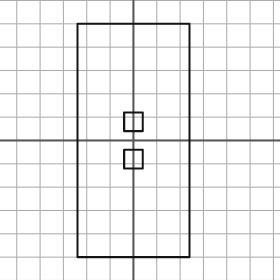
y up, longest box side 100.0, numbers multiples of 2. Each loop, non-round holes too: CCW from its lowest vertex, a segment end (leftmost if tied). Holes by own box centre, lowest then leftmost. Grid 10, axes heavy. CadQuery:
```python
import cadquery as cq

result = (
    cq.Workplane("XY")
    .moveTo(-24.0, -50.0)
    .lineTo(24.0, -50.0)
    .lineTo(24.0, 50.0)
    .lineTo(-24.0, 50.0)
    .close()
    .moveTo(-4.0, -12.0)
    .lineTo(4.0, -12.0)
    .lineTo(4.0, -4.0)
    .lineTo(-4.0, -4.0)
    .close()
    .moveTo(-4.0, 4.0)
    .lineTo(4.0, 4.0)
    .lineTo(4.0, 12.0)
    .lineTo(-4.0, 12.0)
    .close()
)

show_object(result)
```